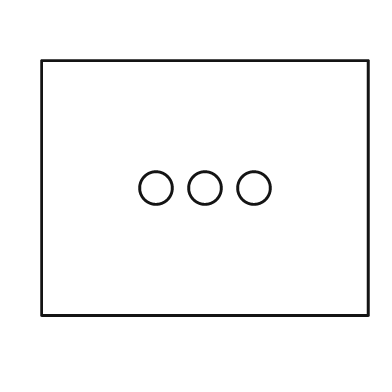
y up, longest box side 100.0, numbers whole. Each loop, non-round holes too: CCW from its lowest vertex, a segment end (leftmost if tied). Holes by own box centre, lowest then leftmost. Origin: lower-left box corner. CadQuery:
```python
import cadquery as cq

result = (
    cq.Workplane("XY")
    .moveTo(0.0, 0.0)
    .lineTo(100.0, 0.0)
    .lineTo(100.0, 78.0)
    .lineTo(0.0, 78.0)
    .close()
    .moveTo(35.0, 39.0)
    .circle(5.0)
    .moveTo(50.0, 39.0)
    .circle(5.0)
    .moveTo(65.0, 39.0)
    .circle(5.0)
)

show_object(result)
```